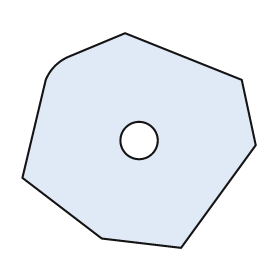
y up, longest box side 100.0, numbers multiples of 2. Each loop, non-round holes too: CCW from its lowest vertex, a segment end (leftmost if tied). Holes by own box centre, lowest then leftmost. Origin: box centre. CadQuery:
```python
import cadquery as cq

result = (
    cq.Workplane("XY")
    .moveTo(18.0, -46.0)
    .lineTo(50.0, -2.0)
    .lineTo(44.0, 26.0)
    .lineTo(-6.0, 46.0)
    .lineTo(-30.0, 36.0)
    .threePointArc((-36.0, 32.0), (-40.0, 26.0))
    .lineTo(-50.0, -16.0)
    .lineTo(-16.0, -42.0)
    .close()
    .moveTo(0.0, 0.0)
    .circle(8.0)
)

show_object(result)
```